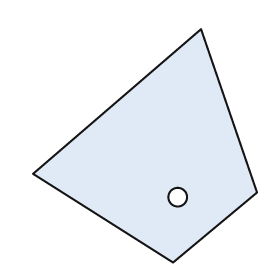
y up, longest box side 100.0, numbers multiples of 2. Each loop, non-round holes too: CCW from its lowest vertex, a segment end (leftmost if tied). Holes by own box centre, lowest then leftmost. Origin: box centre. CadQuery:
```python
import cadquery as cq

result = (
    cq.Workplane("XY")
    .moveTo(12.0, -50.0)
    .lineTo(48.0, -20.0)
    .lineTo(24.0, 50.0)
    .lineTo(-48.0, -12.0)
    .close()
    .moveTo(14.0, -22.0)
    .circle(4.0)
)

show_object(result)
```